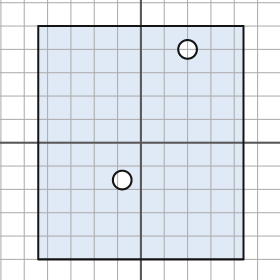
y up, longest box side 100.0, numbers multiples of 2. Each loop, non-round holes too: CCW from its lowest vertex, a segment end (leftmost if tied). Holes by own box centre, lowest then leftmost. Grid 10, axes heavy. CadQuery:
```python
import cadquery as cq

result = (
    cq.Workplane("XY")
    .moveTo(-44.0, -50.0)
    .lineTo(44.0, -50.0)
    .lineTo(44.0, 50.0)
    .lineTo(-44.0, 50.0)
    .close()
    .moveTo(-8.0, -16.0)
    .circle(4.0)
    .moveTo(20.0, 40.0)
    .circle(4.0)
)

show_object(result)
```